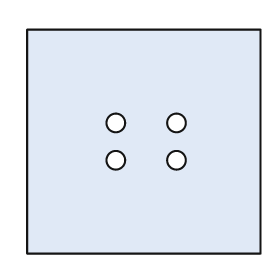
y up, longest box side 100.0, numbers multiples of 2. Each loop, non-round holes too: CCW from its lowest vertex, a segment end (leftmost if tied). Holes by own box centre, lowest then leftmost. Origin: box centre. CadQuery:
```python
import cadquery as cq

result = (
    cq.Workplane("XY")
    .moveTo(-50.0, -48.0)
    .lineTo(50.0, -48.0)
    .lineTo(50.0, 48.0)
    .lineTo(-50.0, 48.0)
    .close()
    .moveTo(-12.0, -8.0)
    .circle(4.0)
    .moveTo(14.0, -8.0)
    .circle(4.0)
    .moveTo(-12.0, 8.0)
    .circle(4.0)
    .moveTo(14.0, 8.0)
    .circle(4.0)
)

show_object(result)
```